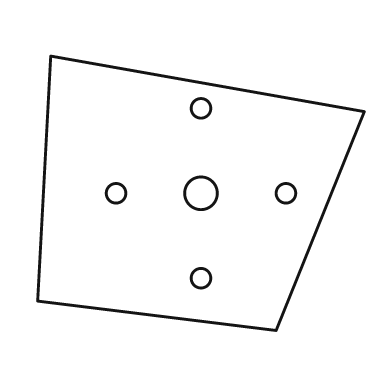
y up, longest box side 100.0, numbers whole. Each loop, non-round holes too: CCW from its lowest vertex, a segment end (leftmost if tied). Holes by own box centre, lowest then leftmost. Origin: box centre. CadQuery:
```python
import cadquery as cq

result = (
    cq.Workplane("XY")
    .moveTo(23.0, -42.0)
    .lineTo(50.0, 25.0)
    .lineTo(-46.0, 42.0)
    .lineTo(-50.0, -33.0)
    .close()
    .moveTo(0.0, -26.0)
    .circle(3.0)
    .moveTo(-26.0, 0.0)
    .circle(3.0)
    .moveTo(0.0, 0.0)
    .circle(5.0)
    .moveTo(26.0, 0.0)
    .circle(3.0)
    .moveTo(0.0, 26.0)
    .circle(3.0)
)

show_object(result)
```